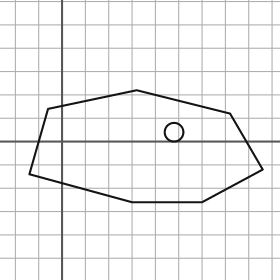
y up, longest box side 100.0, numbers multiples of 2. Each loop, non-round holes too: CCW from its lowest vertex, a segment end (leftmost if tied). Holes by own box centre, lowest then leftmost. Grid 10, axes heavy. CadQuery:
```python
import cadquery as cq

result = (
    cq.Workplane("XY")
    .moveTo(30.0, -26.0)
    .lineTo(60.0, -26.0)
    .lineTo(86.0, -12.0)
    .lineTo(72.0, 12.0)
    .lineTo(32.0, 22.0)
    .lineTo(-6.0, 14.0)
    .lineTo(-14.0, -14.0)
    .close()
    .moveTo(48.0, 4.0)
    .circle(4.0)
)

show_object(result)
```